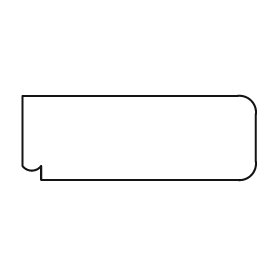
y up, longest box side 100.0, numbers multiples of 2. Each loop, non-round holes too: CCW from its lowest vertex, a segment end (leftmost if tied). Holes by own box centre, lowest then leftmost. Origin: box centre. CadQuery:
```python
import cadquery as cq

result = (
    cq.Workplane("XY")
    .moveTo(-42.0, -18.0)
    .lineTo(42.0, -18.0)
    .threePointArc((48.0, -16.0), (50.0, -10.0))
    .lineTo(50.0, 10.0)
    .threePointArc((48.0, 16.0), (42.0, 18.0))
    .lineTo(-50.0, 18.0)
    .lineTo(-50.0, -12.0)
    .threePointArc((-46.0, -14.0), (-42.0, -12.0))
    .close()
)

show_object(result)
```